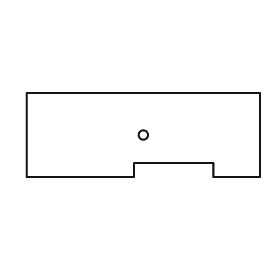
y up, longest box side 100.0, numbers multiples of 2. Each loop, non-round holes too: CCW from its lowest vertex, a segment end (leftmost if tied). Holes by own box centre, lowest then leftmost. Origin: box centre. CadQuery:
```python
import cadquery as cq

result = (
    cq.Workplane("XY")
    .moveTo(-50.0, -18.0)
    .lineTo(-4.0, -18.0)
    .lineTo(-4.0, -12.0)
    .lineTo(30.0, -12.0)
    .lineTo(30.0, -18.0)
    .lineTo(50.0, -18.0)
    .lineTo(50.0, 18.0)
    .lineTo(-50.0, 18.0)
    .close()
    .moveTo(0.0, 0.0)
    .circle(2.0)
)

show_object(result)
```